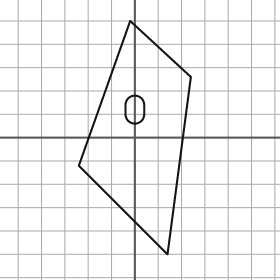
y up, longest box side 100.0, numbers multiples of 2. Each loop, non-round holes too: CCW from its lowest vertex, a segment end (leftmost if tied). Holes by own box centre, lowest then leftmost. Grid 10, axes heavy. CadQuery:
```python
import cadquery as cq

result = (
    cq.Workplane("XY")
    .moveTo(14.0, -50.0)
    .lineTo(24.0, 26.0)
    .lineTo(-2.0, 50.0)
    .lineTo(-24.0, -12.0)
    .close()
    .moveTo(-4.0, 10.0)
    .threePointArc((0.0, 6.0), (4.0, 10.0))
    .lineTo(4.0, 14.0)
    .threePointArc((0.0, 18.0), (-4.0, 14.0))
    .close()
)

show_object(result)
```